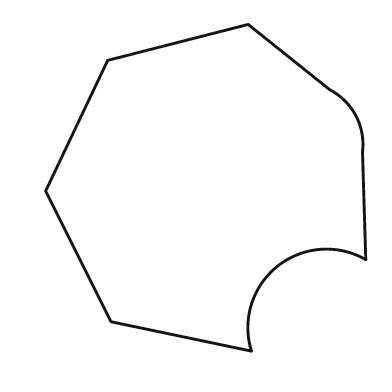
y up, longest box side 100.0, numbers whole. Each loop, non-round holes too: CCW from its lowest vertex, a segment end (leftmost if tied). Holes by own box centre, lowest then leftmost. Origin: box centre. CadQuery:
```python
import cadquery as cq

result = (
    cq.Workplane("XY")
    .moveTo(14.0, -50.0)
    .threePointArc((22.0, -24.0), (49.0, -22.0))
    .lineTo(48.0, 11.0)
    .threePointArc((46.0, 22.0), (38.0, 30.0))
    .lineTo(13.0, 50.0)
    .lineTo(-30.0, 39.0)
    .lineTo(-49.0, -1.0)
    .lineTo(-29.0, -41.0)
    .close()
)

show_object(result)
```